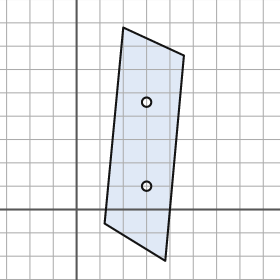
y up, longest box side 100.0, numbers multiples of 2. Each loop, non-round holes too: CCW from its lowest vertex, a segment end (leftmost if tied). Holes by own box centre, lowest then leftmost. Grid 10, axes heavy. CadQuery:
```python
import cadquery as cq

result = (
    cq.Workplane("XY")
    .moveTo(38.0, -22.0)
    .lineTo(46.0, 66.0)
    .lineTo(20.0, 78.0)
    .lineTo(12.0, -6.0)
    .close()
    .moveTo(30.0, 10.0)
    .circle(2.0)
    .moveTo(30.0, 46.0)
    .circle(2.0)
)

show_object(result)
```